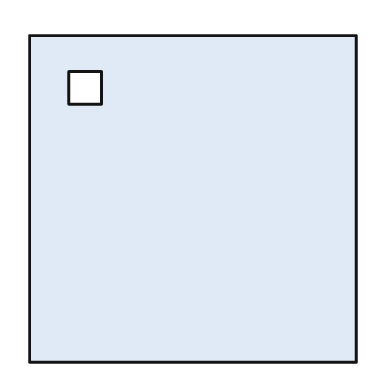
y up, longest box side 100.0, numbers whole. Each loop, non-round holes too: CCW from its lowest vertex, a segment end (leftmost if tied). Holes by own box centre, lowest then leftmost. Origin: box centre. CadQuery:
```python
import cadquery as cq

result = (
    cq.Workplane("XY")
    .moveTo(-50.0, -50.0)
    .lineTo(50.0, -50.0)
    .lineTo(50.0, 50.0)
    .lineTo(-50.0, 50.0)
    .close()
    .moveTo(-38.0, 29.0)
    .lineTo(-28.0, 29.0)
    .lineTo(-28.0, 39.0)
    .lineTo(-38.0, 39.0)
    .close()
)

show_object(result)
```